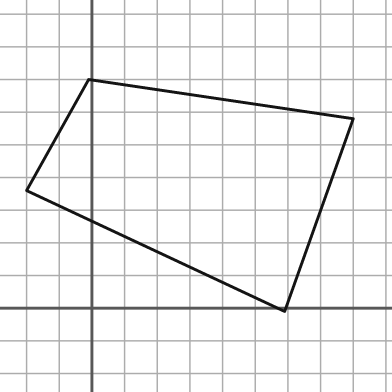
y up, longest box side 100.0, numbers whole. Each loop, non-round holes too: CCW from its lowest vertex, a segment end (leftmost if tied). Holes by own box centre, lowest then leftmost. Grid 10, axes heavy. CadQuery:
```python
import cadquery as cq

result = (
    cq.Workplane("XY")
    .moveTo(59.0, -1.0)
    .lineTo(80.0, 58.0)
    .lineTo(-1.0, 70.0)
    .lineTo(-20.0, 36.0)
    .close()
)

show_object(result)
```